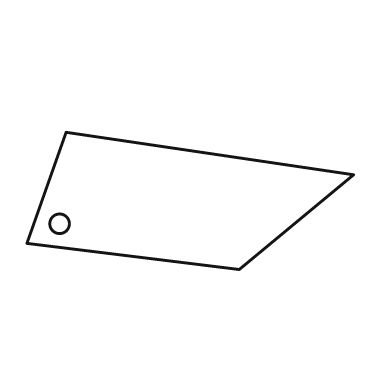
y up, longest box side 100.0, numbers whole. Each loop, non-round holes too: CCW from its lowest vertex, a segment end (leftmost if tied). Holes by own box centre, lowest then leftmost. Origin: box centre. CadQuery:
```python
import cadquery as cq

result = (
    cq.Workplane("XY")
    .moveTo(15.0, -21.0)
    .lineTo(50.0, 8.0)
    .lineTo(-38.0, 21.0)
    .lineTo(-50.0, -13.0)
    .close()
    .moveTo(-40.0, -7.0)
    .circle(3.0)
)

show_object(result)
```